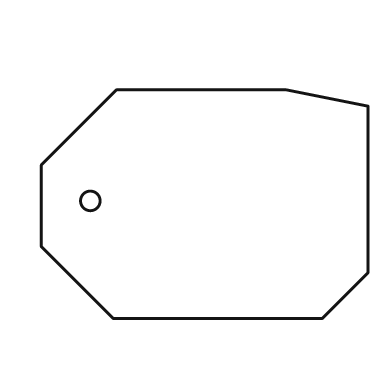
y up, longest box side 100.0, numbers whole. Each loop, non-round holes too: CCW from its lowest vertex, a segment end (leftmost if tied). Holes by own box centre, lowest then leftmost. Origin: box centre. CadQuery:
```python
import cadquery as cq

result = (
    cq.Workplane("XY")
    .moveTo(-28.0, -35.0)
    .lineTo(36.0, -35.0)
    .lineTo(50.0, -21.0)
    .lineTo(50.0, 30.0)
    .lineTo(25.0, 35.0)
    .lineTo(-27.0, 35.0)
    .lineTo(-50.0, 12.0)
    .lineTo(-50.0, -13.0)
    .close()
    .moveTo(-35.0, 1.0)
    .circle(3.0)
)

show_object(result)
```